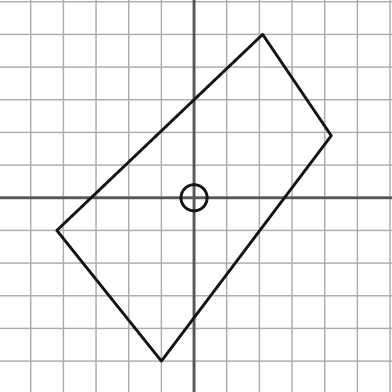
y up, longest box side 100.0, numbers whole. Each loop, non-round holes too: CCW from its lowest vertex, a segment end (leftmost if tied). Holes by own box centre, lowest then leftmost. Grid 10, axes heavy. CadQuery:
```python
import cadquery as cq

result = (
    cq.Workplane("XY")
    .moveTo(-10.0, -50.0)
    .lineTo(42.0, 19.0)
    .lineTo(21.0, 50.0)
    .lineTo(-42.0, -10.0)
    .close()
    .moveTo(0.0, 0.0)
    .circle(4.0)
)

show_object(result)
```